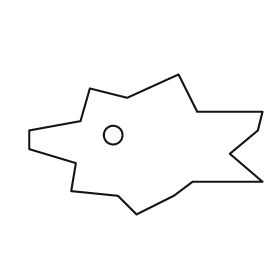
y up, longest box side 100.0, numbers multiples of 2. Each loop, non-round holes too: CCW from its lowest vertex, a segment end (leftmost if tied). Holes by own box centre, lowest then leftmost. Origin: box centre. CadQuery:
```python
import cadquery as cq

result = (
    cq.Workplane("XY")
    .moveTo(-4.0, -30.0)
    .lineTo(12.0, -22.0)
    .lineTo(20.0, -16.0)
    .lineTo(50.0, -16.0)
    .lineTo(36.0, -4.0)
    .lineTo(48.0, 6.0)
    .lineTo(50.0, 14.0)
    .lineTo(22.0, 14.0)
    .lineTo(14.0, 30.0)
    .lineTo(-8.0, 20.0)
    .lineTo(-24.0, 24.0)
    .lineTo(-28.0, 10.0)
    .lineTo(-50.0, 6.0)
    .lineTo(-50.0, -2.0)
    .lineTo(-30.0, -8.0)
    .lineTo(-32.0, -20.0)
    .lineTo(-12.0, -22.0)
    .close()
    .moveTo(-14.0, 4.0)
    .circle(4.0)
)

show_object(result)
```